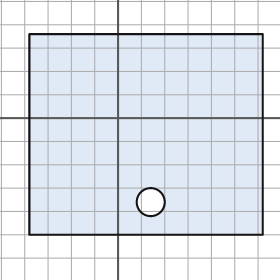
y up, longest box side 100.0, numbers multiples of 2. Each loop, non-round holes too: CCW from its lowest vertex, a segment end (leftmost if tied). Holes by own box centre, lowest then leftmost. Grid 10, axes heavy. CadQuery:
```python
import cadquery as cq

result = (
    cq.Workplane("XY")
    .moveTo(-38.0, -50.0)
    .lineTo(62.0, -50.0)
    .lineTo(62.0, 36.0)
    .lineTo(-38.0, 36.0)
    .close()
    .moveTo(14.0, -36.0)
    .circle(6.0)
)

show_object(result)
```